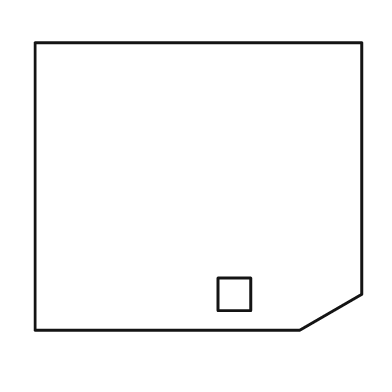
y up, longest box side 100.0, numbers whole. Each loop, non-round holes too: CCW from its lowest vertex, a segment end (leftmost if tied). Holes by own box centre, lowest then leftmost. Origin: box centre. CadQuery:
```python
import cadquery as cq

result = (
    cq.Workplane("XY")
    .moveTo(-50.0, -44.0)
    .lineTo(31.0, -44.0)
    .lineTo(50.0, -33.0)
    .lineTo(50.0, 44.0)
    .lineTo(-50.0, 44.0)
    .close()
    .moveTo(6.0, -38.0)
    .lineTo(16.0, -38.0)
    .lineTo(16.0, -28.0)
    .lineTo(6.0, -28.0)
    .close()
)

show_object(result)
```